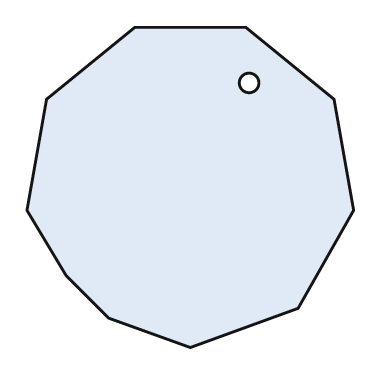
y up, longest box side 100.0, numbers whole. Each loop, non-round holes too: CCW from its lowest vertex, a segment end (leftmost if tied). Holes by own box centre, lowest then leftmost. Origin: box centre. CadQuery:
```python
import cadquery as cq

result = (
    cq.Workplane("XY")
    .moveTo(0.0, -49.0)
    .lineTo(33.0, -37.0)
    .lineTo(50.0, -7.0)
    .lineTo(44.0, 27.0)
    .lineTo(17.0, 49.0)
    .lineTo(-17.0, 49.0)
    .lineTo(-44.0, 27.0)
    .lineTo(-50.0, -7.0)
    .lineTo(-38.0, -27.0)
    .lineTo(-25.0, -40.0)
    .close()
    .moveTo(18.0, 32.0)
    .circle(3.0)
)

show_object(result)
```